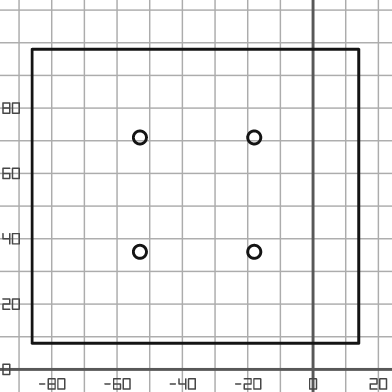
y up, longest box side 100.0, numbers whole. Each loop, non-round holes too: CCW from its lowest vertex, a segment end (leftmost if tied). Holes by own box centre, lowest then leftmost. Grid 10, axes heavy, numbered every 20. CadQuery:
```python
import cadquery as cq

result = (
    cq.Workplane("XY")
    .moveTo(-86.0, 8.0)
    .lineTo(14.0, 8.0)
    .lineTo(14.0, 98.0)
    .lineTo(-86.0, 98.0)
    .close()
    .moveTo(-53.0, 36.0)
    .circle(2.0)
    .moveTo(-18.0, 36.0)
    .circle(2.0)
    .moveTo(-53.0, 71.0)
    .circle(2.0)
    .moveTo(-18.0, 71.0)
    .circle(2.0)
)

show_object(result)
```